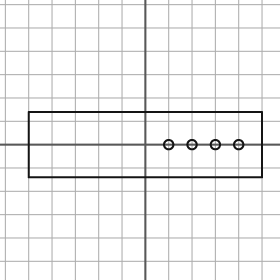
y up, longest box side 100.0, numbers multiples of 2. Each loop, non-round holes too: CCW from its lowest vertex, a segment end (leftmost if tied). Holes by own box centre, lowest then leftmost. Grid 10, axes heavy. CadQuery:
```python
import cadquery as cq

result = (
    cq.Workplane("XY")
    .moveTo(-50.0, -14.0)
    .lineTo(50.0, -14.0)
    .lineTo(50.0, 14.0)
    .lineTo(-50.0, 14.0)
    .close()
    .moveTo(10.0, 0.0)
    .circle(2.0)
    .moveTo(20.0, 0.0)
    .circle(2.0)
    .moveTo(30.0, 0.0)
    .circle(2.0)
    .moveTo(40.0, 0.0)
    .circle(2.0)
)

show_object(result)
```